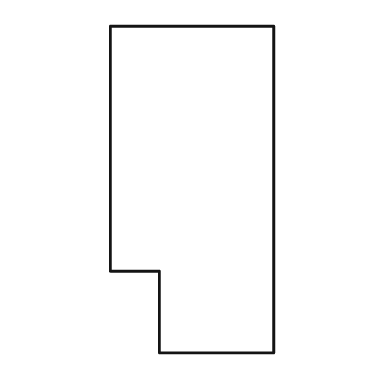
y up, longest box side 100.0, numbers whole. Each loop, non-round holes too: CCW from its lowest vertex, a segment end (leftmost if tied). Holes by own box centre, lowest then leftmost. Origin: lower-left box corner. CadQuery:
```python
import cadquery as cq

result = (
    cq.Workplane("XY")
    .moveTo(15.0, 0.0)
    .lineTo(50.0, 0.0)
    .lineTo(50.0, 100.0)
    .lineTo(0.0, 100.0)
    .lineTo(0.0, 25.0)
    .lineTo(15.0, 25.0)
    .close()
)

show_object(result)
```